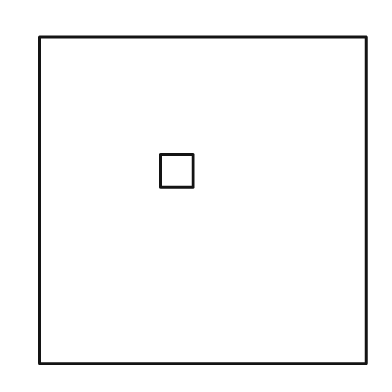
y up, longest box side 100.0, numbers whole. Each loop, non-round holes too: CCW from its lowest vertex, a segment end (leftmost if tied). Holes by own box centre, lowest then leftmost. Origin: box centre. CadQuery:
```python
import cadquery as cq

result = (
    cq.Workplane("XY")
    .moveTo(-50.0, -50.0)
    .lineTo(50.0, -50.0)
    .lineTo(50.0, 50.0)
    .lineTo(-50.0, 50.0)
    .close()
    .moveTo(-13.0, 4.0)
    .lineTo(-3.0, 4.0)
    .lineTo(-3.0, 14.0)
    .lineTo(-13.0, 14.0)
    .close()
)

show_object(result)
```